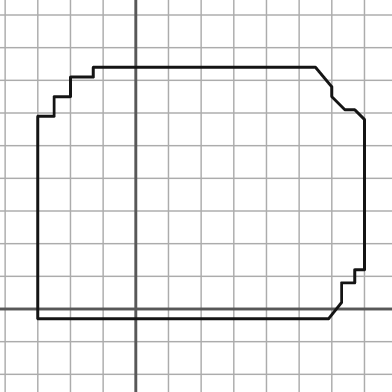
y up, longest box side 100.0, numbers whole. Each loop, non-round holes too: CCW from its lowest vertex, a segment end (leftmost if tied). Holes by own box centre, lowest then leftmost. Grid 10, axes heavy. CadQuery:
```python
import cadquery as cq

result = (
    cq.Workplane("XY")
    .moveTo(-30.0, -3.0)
    .lineTo(59.0, -3.0)
    .lineTo(63.0, 2.0)
    .lineTo(63.0, 8.0)
    .lineTo(67.0, 8.0)
    .lineTo(67.0, 12.0)
    .lineTo(70.0, 12.0)
    .lineTo(70.0, 58.0)
    .lineTo(67.0, 61.0)
    .lineTo(64.0, 61.0)
    .lineTo(60.0, 65.0)
    .lineTo(60.0, 68.0)
    .lineTo(55.0, 74.0)
    .lineTo(-13.0, 74.0)
    .lineTo(-13.0, 71.0)
    .lineTo(-20.0, 71.0)
    .lineTo(-20.0, 65.0)
    .lineTo(-25.0, 65.0)
    .lineTo(-25.0, 59.0)
    .lineTo(-30.0, 59.0)
    .close()
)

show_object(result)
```